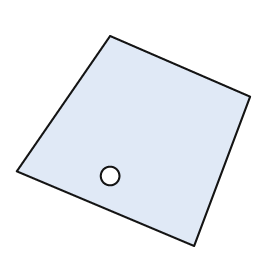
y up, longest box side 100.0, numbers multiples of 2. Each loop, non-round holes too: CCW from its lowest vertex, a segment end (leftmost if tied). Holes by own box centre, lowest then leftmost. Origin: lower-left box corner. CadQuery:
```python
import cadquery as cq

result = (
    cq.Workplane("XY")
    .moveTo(76.0, 0.0)
    .lineTo(100.0, 64.0)
    .lineTo(40.0, 90.0)
    .lineTo(0.0, 32.0)
    .close()
    .moveTo(40.0, 30.0)
    .circle(4.0)
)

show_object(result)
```